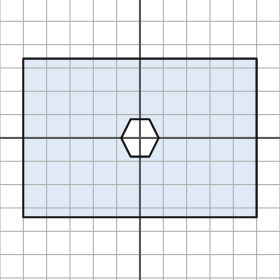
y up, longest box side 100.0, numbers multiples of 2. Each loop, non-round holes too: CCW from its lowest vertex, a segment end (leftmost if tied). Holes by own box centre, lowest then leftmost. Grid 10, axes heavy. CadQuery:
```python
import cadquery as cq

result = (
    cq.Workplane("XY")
    .moveTo(-50.0, -34.0)
    .lineTo(50.0, -34.0)
    .lineTo(50.0, 34.0)
    .lineTo(-50.0, 34.0)
    .close()
    .moveTo(-4.0, -8.0)
    .lineTo(4.0, -8.0)
    .lineTo(8.0, 0.0)
    .lineTo(4.0, 8.0)
    .lineTo(-4.0, 8.0)
    .lineTo(-8.0, 0.0)
    .close()
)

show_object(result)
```